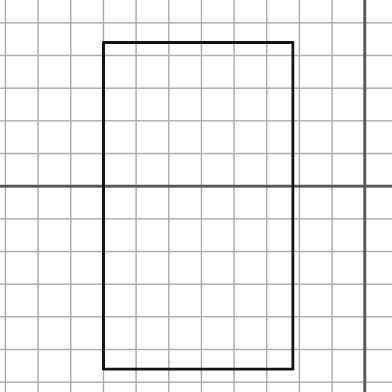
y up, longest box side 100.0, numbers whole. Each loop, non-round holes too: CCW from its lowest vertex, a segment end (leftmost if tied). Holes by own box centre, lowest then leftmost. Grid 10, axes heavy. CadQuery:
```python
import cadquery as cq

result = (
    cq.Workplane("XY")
    .moveTo(-80.0, -56.0)
    .lineTo(-22.0, -56.0)
    .lineTo(-22.0, 44.0)
    .lineTo(-80.0, 44.0)
    .close()
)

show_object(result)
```